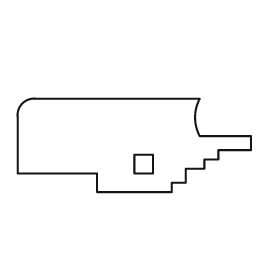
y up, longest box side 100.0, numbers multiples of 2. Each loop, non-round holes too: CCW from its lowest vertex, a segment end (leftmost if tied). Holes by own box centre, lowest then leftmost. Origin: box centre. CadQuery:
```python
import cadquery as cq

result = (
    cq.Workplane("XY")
    .moveTo(-16.0, -20.0)
    .lineTo(16.0, -20.0)
    .lineTo(16.0, -16.0)
    .lineTo(22.0, -16.0)
    .lineTo(22.0, -10.0)
    .lineTo(30.0, -10.0)
    .lineTo(30.0, -6.0)
    .lineTo(36.0, -6.0)
    .lineTo(36.0, -2.0)
    .lineTo(50.0, -2.0)
    .lineTo(50.0, 4.0)
    .lineTo(28.0, 4.0)
    .threePointArc((26.0, 12.0), (28.0, 20.0))
    .lineTo(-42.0, 20.0)
    .threePointArc((-48.0, 18.0), (-50.0, 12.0))
    .lineTo(-50.0, -12.0)
    .lineTo(-16.0, -12.0)
    .close()
    .moveTo(0.0, -12.0)
    .lineTo(8.0, -12.0)
    .lineTo(8.0, -4.0)
    .lineTo(0.0, -4.0)
    .close()
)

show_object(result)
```